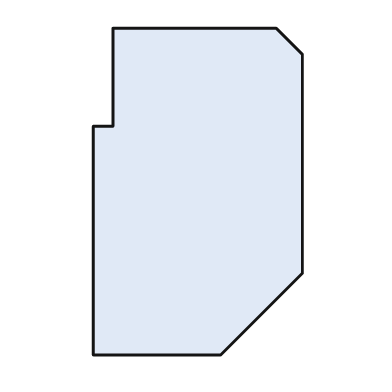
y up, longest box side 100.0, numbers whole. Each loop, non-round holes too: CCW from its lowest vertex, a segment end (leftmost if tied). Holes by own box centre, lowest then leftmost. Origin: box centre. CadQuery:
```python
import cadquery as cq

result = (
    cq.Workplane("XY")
    .moveTo(-32.0, -50.0)
    .lineTo(7.0, -50.0)
    .lineTo(32.0, -25.0)
    .lineTo(32.0, 42.0)
    .lineTo(24.0, 50.0)
    .lineTo(-26.0, 50.0)
    .lineTo(-26.0, 20.0)
    .lineTo(-32.0, 20.0)
    .close()
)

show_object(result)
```